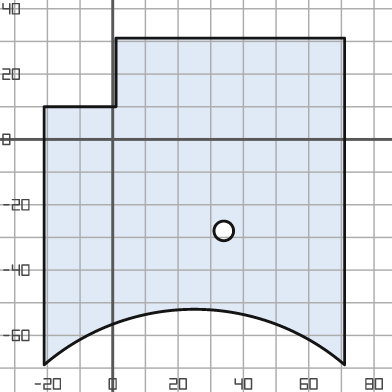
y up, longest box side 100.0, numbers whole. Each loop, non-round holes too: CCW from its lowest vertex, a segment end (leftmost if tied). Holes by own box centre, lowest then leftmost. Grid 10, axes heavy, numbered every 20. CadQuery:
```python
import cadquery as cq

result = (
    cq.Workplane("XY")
    .moveTo(-21.0, -69.0)
    .threePointArc((25.0, -52.0), (71.0, -69.0))
    .lineTo(71.0, 31.0)
    .lineTo(1.0, 31.0)
    .lineTo(1.0, 10.0)
    .lineTo(-21.0, 10.0)
    .close()
    .moveTo(34.0, -28.0)
    .circle(3.0)
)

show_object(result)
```